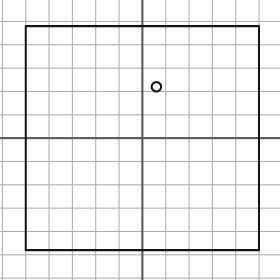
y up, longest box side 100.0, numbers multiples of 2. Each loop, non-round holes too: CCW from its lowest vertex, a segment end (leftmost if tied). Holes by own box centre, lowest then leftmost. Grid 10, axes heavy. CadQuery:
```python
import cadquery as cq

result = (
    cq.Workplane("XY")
    .moveTo(-50.0, -48.0)
    .lineTo(50.0, -48.0)
    .lineTo(50.0, 48.0)
    .lineTo(-50.0, 48.0)
    .close()
    .moveTo(6.0, 22.0)
    .circle(2.0)
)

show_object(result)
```